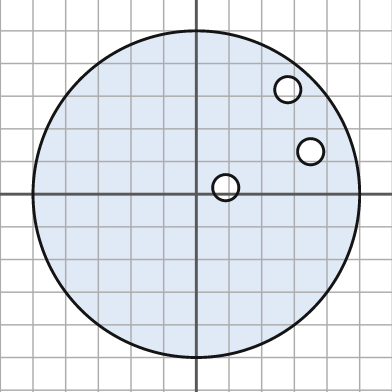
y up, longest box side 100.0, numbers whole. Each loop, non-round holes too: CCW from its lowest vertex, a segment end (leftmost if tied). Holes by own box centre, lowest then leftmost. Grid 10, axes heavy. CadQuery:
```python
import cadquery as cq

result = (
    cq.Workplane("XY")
    .moveTo(0.0, 0.0)
    .circle(50.0)
    .moveTo(9.0, 2.0)
    .circle(4.0)
    .moveTo(35.0, 13.0)
    .circle(4.0)
    .moveTo(28.0, 32.0)
    .circle(4.0)
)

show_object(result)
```